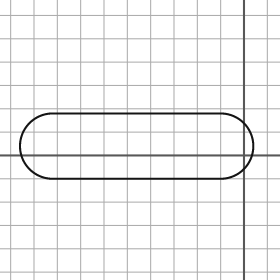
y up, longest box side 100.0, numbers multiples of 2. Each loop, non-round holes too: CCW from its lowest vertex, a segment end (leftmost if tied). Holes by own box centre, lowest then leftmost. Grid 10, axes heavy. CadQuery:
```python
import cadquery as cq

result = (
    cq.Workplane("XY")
    .moveTo(-82.0, -10.0)
    .lineTo(-10.0, -10.0)
    .threePointArc((4.0, 4.0), (-10.0, 18.0))
    .lineTo(-82.0, 18.0)
    .threePointArc((-96.0, 4.0), (-82.0, -10.0))
    .close()
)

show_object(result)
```